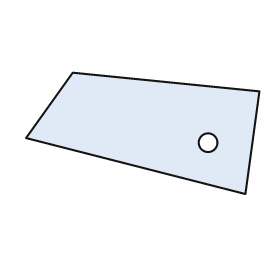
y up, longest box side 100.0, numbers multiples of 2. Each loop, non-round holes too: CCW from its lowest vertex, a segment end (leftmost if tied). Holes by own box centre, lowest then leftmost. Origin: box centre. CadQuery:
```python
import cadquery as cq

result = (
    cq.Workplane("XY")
    .moveTo(44.0, -26.0)
    .lineTo(50.0, 18.0)
    .lineTo(-30.0, 26.0)
    .lineTo(-50.0, -2.0)
    .close()
    .moveTo(28.0, -4.0)
    .circle(4.0)
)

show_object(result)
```